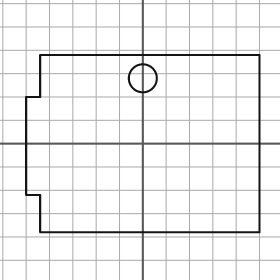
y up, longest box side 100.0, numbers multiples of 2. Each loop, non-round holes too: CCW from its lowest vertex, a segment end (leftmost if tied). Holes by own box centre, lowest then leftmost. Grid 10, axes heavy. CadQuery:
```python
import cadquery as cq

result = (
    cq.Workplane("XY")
    .moveTo(-44.0, -38.0)
    .lineTo(50.0, -38.0)
    .lineTo(50.0, 38.0)
    .lineTo(-44.0, 38.0)
    .lineTo(-44.0, 20.0)
    .lineTo(-50.0, 20.0)
    .lineTo(-50.0, -22.0)
    .lineTo(-44.0, -22.0)
    .close()
    .moveTo(0.0, 28.0)
    .circle(6.0)
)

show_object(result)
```